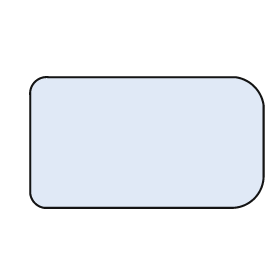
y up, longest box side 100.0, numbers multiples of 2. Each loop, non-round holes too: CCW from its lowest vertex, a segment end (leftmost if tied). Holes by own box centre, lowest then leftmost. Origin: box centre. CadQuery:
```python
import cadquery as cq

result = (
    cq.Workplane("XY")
    .moveTo(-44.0, -28.0)
    .lineTo(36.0, -28.0)
    .threePointArc((46.0, -24.0), (50.0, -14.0))
    .lineTo(50.0, 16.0)
    .threePointArc((46.0, 24.0), (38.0, 28.0))
    .lineTo(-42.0, 28.0)
    .threePointArc((-48.0, 26.0), (-50.0, 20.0))
    .lineTo(-50.0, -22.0)
    .threePointArc((-48.0, -26.0), (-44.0, -28.0))
    .close()
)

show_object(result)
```